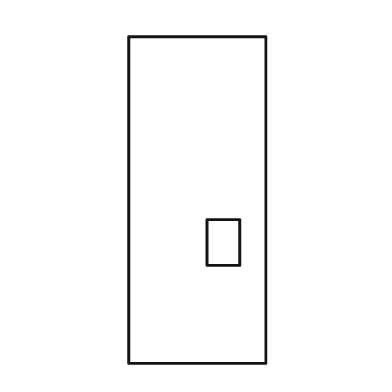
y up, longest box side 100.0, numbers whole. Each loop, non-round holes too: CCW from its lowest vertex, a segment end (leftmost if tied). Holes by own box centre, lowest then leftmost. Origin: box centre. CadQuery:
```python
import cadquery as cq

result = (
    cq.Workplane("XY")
    .moveTo(-21.0, -50.0)
    .lineTo(21.0, -50.0)
    .lineTo(21.0, 50.0)
    .lineTo(-21.0, 50.0)
    .close()
    .moveTo(3.0, -20.0)
    .lineTo(13.0, -20.0)
    .lineTo(13.0, -6.0)
    .lineTo(3.0, -6.0)
    .close()
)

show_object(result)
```